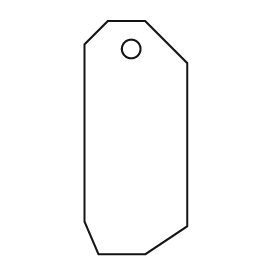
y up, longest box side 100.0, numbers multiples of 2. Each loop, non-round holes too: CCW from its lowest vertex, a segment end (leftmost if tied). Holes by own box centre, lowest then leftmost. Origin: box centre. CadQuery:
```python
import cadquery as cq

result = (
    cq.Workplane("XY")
    .moveTo(-16.0, -50.0)
    .lineTo(4.0, -50.0)
    .lineTo(22.0, -38.0)
    .lineTo(22.0, 32.0)
    .lineTo(4.0, 50.0)
    .lineTo(-12.0, 50.0)
    .lineTo(-22.0, 40.0)
    .lineTo(-22.0, -36.0)
    .close()
    .moveTo(-2.0, 38.0)
    .circle(4.0)
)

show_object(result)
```